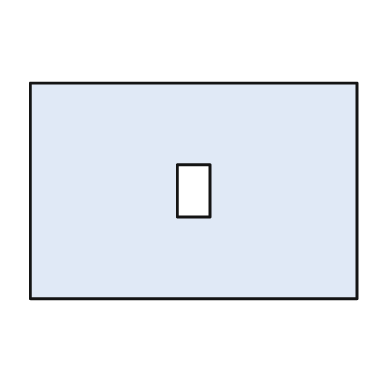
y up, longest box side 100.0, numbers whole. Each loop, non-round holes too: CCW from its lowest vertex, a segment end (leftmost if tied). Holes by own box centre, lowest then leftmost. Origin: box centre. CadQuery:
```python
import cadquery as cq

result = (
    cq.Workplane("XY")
    .moveTo(-50.0, -33.0)
    .lineTo(50.0, -33.0)
    .lineTo(50.0, 33.0)
    .lineTo(-50.0, 33.0)
    .close()
    .moveTo(-5.0, -8.0)
    .lineTo(5.0, -8.0)
    .lineTo(5.0, 8.0)
    .lineTo(-5.0, 8.0)
    .close()
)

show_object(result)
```